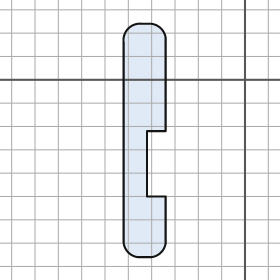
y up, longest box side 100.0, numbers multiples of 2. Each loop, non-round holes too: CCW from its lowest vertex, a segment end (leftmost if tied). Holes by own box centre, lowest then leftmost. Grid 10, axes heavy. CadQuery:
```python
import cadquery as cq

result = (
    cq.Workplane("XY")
    .moveTo(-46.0, -76.0)
    .lineTo(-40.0, -76.0)
    .threePointArc((-36.0, -74.0), (-34.0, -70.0))
    .lineTo(-34.0, -50.0)
    .lineTo(-42.0, -50.0)
    .lineTo(-42.0, -22.0)
    .lineTo(-34.0, -22.0)
    .lineTo(-34.0, 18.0)
    .threePointArc((-36.0, 22.0), (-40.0, 24.0))
    .lineTo(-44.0, 24.0)
    .threePointArc((-50.0, 22.0), (-52.0, 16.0))
    .lineTo(-52.0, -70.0)
    .threePointArc((-50.0, -74.0), (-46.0, -76.0))
    .close()
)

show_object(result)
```